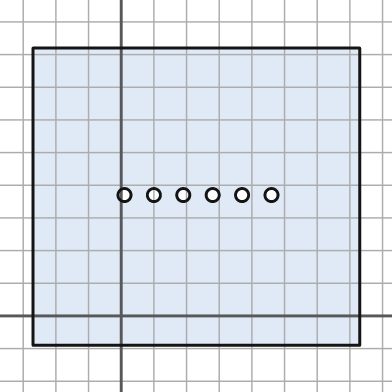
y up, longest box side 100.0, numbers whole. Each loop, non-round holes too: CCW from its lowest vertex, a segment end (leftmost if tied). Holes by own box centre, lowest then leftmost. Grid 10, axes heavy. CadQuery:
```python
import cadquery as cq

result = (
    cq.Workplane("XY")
    .moveTo(-27.0, -9.0)
    .lineTo(73.0, -9.0)
    .lineTo(73.0, 82.0)
    .lineTo(-27.0, 82.0)
    .close()
    .moveTo(1.0, 37.0)
    .circle(2.0)
    .moveTo(10.0, 37.0)
    .circle(2.0)
    .moveTo(19.0, 37.0)
    .circle(2.0)
    .moveTo(28.0, 37.0)
    .circle(2.0)
    .moveTo(37.0, 37.0)
    .circle(2.0)
    .moveTo(46.0, 37.0)
    .circle(2.0)
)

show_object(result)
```